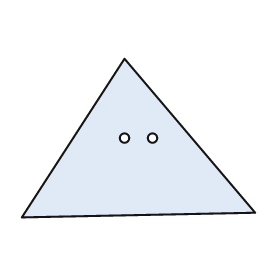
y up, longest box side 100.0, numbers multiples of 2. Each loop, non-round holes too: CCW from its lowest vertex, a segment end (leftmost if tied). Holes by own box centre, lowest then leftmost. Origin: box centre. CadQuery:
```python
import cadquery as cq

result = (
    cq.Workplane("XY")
    .moveTo(-50.0, -34.0)
    .lineTo(50.0, -32.0)
    .lineTo(-6.0, 34.0)
    .close()
    .moveTo(-6.0, 0.0)
    .circle(2.0)
    .moveTo(6.0, 0.0)
    .circle(2.0)
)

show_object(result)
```